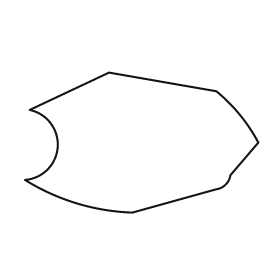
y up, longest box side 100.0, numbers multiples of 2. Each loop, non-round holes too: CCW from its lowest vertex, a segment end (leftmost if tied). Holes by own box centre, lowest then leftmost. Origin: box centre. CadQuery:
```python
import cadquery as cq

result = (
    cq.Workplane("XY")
    .moveTo(-4.0, -30.0)
    .lineTo(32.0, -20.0)
    .threePointArc((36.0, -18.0), (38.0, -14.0))
    .lineTo(50.0, 0.0)
    .threePointArc((42.0, 12.0), (32.0, 22.0))
    .lineTo(-14.0, 30.0)
    .lineTo(-48.0, 14.0)
    .threePointArc((-36.0, -2.0), (-50.0, -16.0))
    .threePointArc((-28.0, -26.0), (-4.0, -30.0))
    .close()
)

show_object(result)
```